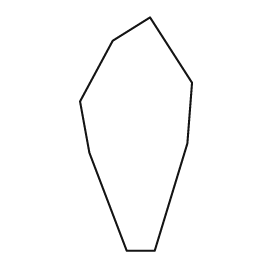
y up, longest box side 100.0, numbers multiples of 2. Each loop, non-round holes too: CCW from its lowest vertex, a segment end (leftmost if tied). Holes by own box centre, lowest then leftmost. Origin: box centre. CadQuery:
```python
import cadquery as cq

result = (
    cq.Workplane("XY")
    .moveTo(-4.0, -50.0)
    .lineTo(8.0, -50.0)
    .lineTo(22.0, -4.0)
    .lineTo(24.0, 22.0)
    .lineTo(6.0, 50.0)
    .lineTo(-10.0, 40.0)
    .lineTo(-24.0, 14.0)
    .lineTo(-20.0, -8.0)
    .close()
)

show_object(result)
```